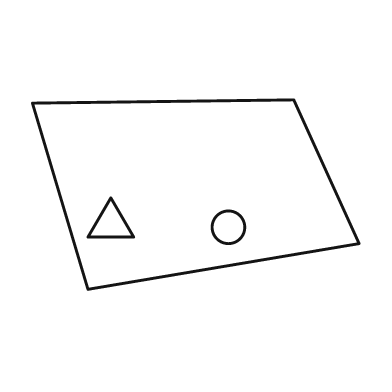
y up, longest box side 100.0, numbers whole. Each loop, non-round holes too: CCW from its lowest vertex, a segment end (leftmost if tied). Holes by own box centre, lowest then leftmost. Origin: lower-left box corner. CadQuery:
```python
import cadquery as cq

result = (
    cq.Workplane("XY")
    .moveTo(17.0, 0.0)
    .lineTo(100.0, 14.0)
    .lineTo(80.0, 58.0)
    .lineTo(0.0, 57.0)
    .close()
    .moveTo(60.0, 19.0)
    .circle(5.0)
    .moveTo(17.0, 16.0)
    .lineTo(31.0, 16.0)
    .lineTo(24.0, 28.0)
    .close()
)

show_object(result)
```